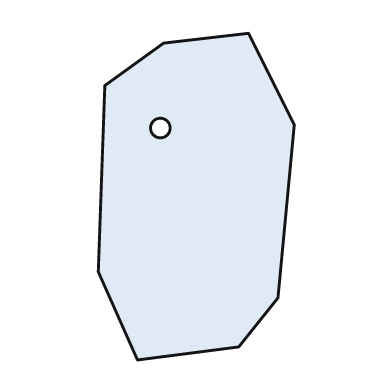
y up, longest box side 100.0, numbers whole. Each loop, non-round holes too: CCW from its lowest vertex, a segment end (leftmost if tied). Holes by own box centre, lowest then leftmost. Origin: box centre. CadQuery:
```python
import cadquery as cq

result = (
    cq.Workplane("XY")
    .moveTo(-18.0, -50.0)
    .lineTo(13.0, -46.0)
    .lineTo(25.0, -31.0)
    .lineTo(30.0, 22.0)
    .lineTo(16.0, 50.0)
    .lineTo(-10.0, 47.0)
    .lineTo(-28.0, 34.0)
    .lineTo(-30.0, -23.0)
    .close()
    .moveTo(-11.0, 21.0)
    .circle(3.0)
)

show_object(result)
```